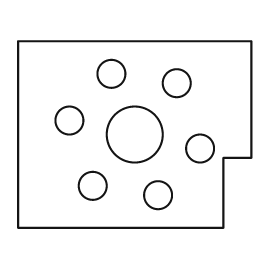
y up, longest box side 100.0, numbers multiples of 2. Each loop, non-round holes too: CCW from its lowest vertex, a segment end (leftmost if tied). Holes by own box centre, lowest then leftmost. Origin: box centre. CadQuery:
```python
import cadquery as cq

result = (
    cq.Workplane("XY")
    .moveTo(-50.0, -40.0)
    .lineTo(38.0, -40.0)
    .lineTo(38.0, -10.0)
    .lineTo(50.0, -10.0)
    .lineTo(50.0, 40.0)
    .lineTo(-50.0, 40.0)
    .close()
    .moveTo(10.0, -26.0)
    .circle(6.0)
    .moveTo(-18.0, -22.0)
    .circle(6.0)
    .moveTo(28.0, -6.0)
    .circle(6.0)
    .moveTo(0.0, 0.0)
    .circle(12.0)
    .moveTo(-28.0, 6.0)
    .circle(6.0)
    .moveTo(18.0, 22.0)
    .circle(6.0)
    .moveTo(-10.0, 26.0)
    .circle(6.0)
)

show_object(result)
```